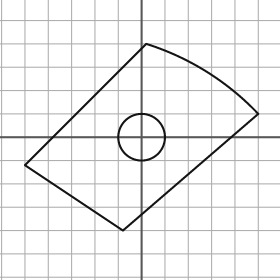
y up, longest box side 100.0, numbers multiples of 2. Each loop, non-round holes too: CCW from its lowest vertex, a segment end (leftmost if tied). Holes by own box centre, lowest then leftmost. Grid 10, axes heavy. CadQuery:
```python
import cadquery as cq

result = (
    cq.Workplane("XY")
    .moveTo(-8.0, -40.0)
    .lineTo(50.0, 10.0)
    .threePointArc((28.0, 28.0), (2.0, 40.0))
    .lineTo(-50.0, -12.0)
    .close()
    .moveTo(0.0, 0.0)
    .circle(10.0)
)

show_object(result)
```